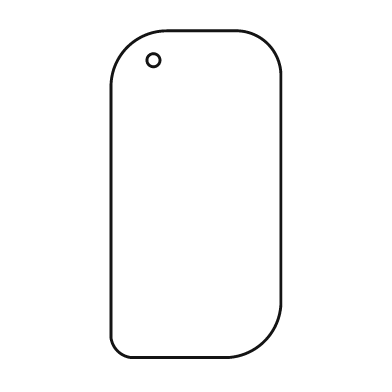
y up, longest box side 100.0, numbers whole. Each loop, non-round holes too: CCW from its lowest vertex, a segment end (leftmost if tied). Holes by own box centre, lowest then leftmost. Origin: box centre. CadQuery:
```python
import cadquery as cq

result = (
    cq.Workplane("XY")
    .moveTo(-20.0, -50.0)
    .lineTo(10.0, -50.0)
    .threePointArc((21.0, -45.0), (26.0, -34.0))
    .lineTo(26.0, 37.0)
    .threePointArc((22.0, 46.0), (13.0, 50.0))
    .lineTo(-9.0, 50.0)
    .threePointArc((-21.0, 45.0), (-26.0, 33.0))
    .lineTo(-26.0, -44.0)
    .threePointArc((-24.0, -48.0), (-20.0, -50.0))
    .close()
    .moveTo(-13.0, 41.0)
    .circle(2.0)
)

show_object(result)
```